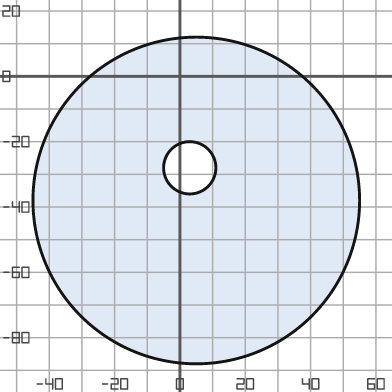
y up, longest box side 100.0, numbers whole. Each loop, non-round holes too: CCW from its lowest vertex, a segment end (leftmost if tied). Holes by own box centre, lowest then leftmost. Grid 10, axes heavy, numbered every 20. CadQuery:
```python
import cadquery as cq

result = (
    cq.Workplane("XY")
    .moveTo(5.0, -38.0)
    .circle(50.0)
    .moveTo(3.0, -28.0)
    .circle(8.0)
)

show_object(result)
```